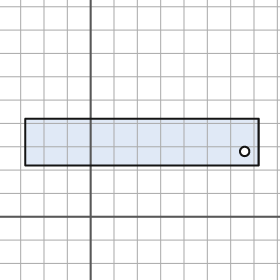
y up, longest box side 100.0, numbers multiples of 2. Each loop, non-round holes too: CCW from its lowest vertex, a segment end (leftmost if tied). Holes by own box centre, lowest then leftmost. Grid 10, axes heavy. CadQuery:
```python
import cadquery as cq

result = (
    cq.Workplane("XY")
    .moveTo(-28.0, 22.0)
    .lineTo(72.0, 22.0)
    .lineTo(72.0, 42.0)
    .lineTo(-28.0, 42.0)
    .close()
    .moveTo(66.0, 28.0)
    .circle(2.0)
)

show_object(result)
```